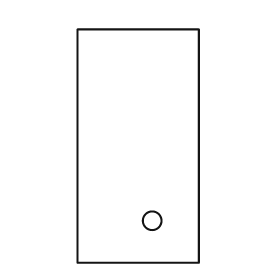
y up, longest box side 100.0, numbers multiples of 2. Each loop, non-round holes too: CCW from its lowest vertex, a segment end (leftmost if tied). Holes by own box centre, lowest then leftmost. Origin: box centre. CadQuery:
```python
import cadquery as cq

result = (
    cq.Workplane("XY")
    .moveTo(-26.0, -50.0)
    .lineTo(26.0, -50.0)
    .lineTo(26.0, 50.0)
    .lineTo(-26.0, 50.0)
    .close()
    .moveTo(6.0, -32.0)
    .circle(4.0)
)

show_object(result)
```